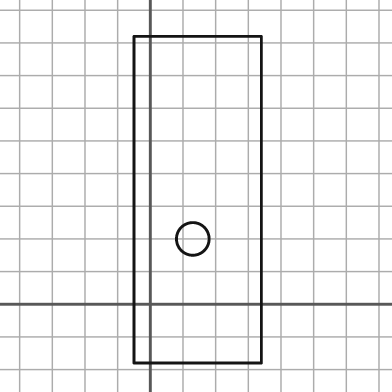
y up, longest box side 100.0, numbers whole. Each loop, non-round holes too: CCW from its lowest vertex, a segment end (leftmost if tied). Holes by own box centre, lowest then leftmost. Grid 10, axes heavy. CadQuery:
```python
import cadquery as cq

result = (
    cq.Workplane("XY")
    .moveTo(-5.0, -18.0)
    .lineTo(34.0, -18.0)
    .lineTo(34.0, 82.0)
    .lineTo(-5.0, 82.0)
    .close()
    .moveTo(13.0, 20.0)
    .circle(5.0)
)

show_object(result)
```